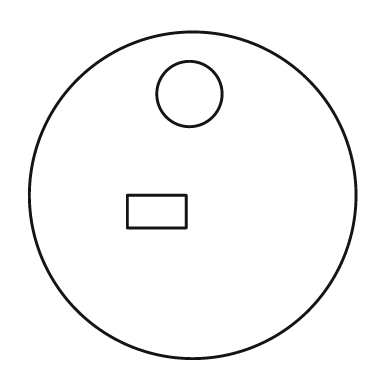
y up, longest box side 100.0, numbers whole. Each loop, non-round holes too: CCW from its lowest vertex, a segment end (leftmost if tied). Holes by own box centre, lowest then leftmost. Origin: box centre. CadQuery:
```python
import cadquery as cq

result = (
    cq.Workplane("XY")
    .moveTo(0.0, 0.0)
    .circle(50.0)
    .moveTo(-20.0, -10.0)
    .lineTo(-2.0, -10.0)
    .lineTo(-2.0, 0.0)
    .lineTo(-20.0, 0.0)
    .close()
    .moveTo(-1.0, 31.0)
    .circle(10.0)
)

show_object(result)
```